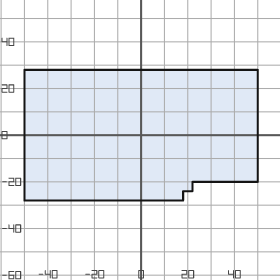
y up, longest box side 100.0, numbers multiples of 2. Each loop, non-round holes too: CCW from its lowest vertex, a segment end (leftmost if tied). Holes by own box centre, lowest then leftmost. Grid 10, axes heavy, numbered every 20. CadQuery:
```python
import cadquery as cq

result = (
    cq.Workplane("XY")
    .moveTo(-50.0, -28.0)
    .lineTo(18.0, -28.0)
    .lineTo(18.0, -24.0)
    .lineTo(22.0, -24.0)
    .lineTo(22.0, -20.0)
    .lineTo(50.0, -20.0)
    .lineTo(50.0, 28.0)
    .lineTo(-50.0, 28.0)
    .close()
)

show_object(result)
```